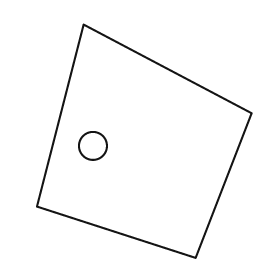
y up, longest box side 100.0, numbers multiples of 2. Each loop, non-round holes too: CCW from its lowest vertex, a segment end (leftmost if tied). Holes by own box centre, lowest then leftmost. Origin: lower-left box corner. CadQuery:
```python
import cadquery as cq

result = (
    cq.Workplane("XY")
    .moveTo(68.0, 0.0)
    .lineTo(92.0, 62.0)
    .lineTo(20.0, 100.0)
    .lineTo(0.0, 22.0)
    .close()
    .moveTo(24.0, 48.0)
    .circle(6.0)
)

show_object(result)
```